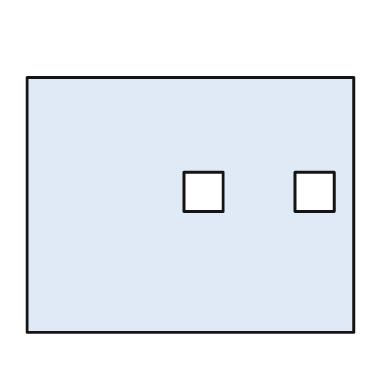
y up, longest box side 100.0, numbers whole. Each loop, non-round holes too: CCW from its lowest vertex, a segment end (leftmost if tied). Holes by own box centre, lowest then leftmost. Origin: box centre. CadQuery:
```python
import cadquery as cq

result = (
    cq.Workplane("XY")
    .moveTo(-50.0, -39.0)
    .lineTo(50.0, -39.0)
    .lineTo(50.0, 39.0)
    .lineTo(-50.0, 39.0)
    .close()
    .moveTo(-2.0, -2.0)
    .lineTo(10.0, -2.0)
    .lineTo(10.0, 10.0)
    .lineTo(-2.0, 10.0)
    .close()
    .moveTo(32.0, -2.0)
    .lineTo(44.0, -2.0)
    .lineTo(44.0, 10.0)
    .lineTo(32.0, 10.0)
    .close()
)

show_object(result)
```